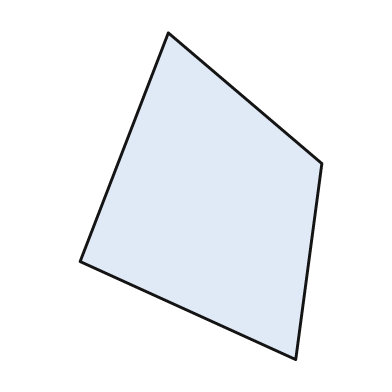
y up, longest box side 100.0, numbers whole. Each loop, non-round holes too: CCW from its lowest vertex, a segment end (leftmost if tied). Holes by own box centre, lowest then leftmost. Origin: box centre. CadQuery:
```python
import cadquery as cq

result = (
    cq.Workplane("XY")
    .moveTo(29.0, -50.0)
    .lineTo(37.0, 10.0)
    .lineTo(-10.0, 50.0)
    .lineTo(-37.0, -20.0)
    .close()
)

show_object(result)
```